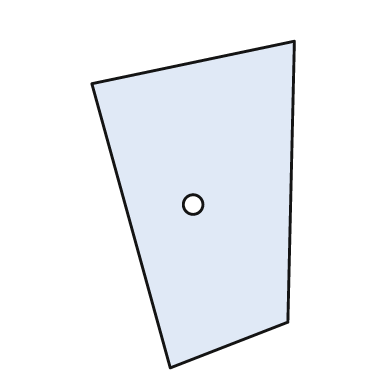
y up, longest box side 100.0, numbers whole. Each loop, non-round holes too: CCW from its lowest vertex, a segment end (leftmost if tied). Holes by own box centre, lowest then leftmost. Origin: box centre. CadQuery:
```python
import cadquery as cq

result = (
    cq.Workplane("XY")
    .moveTo(-7.0, -50.0)
    .lineTo(29.0, -36.0)
    .lineTo(31.0, 50.0)
    .lineTo(-31.0, 37.0)
    .close()
    .moveTo(0.0, 0.0)
    .circle(3.0)
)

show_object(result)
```